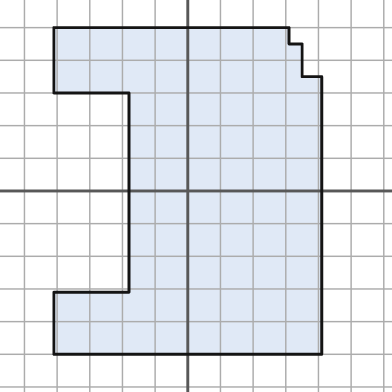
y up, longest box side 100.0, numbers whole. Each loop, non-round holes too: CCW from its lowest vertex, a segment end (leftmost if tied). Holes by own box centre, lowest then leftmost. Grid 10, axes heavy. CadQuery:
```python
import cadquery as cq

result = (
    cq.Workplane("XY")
    .moveTo(-41.0, -50.0)
    .lineTo(41.0, -50.0)
    .lineTo(41.0, 35.0)
    .lineTo(35.0, 35.0)
    .lineTo(35.0, 45.0)
    .lineTo(31.0, 45.0)
    .lineTo(31.0, 50.0)
    .lineTo(-41.0, 50.0)
    .lineTo(-41.0, 30.0)
    .lineTo(-18.0, 30.0)
    .lineTo(-18.0, -31.0)
    .lineTo(-41.0, -31.0)
    .close()
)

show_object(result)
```